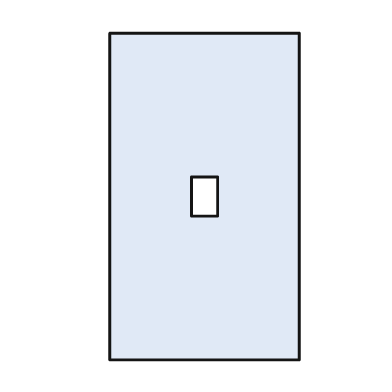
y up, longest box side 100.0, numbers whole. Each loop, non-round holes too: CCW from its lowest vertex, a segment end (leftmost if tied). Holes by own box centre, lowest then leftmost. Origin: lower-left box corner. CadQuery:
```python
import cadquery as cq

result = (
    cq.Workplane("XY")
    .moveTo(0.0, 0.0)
    .lineTo(58.0, 0.0)
    .lineTo(58.0, 100.0)
    .lineTo(0.0, 100.0)
    .close()
    .moveTo(25.0, 44.0)
    .lineTo(33.0, 44.0)
    .lineTo(33.0, 56.0)
    .lineTo(25.0, 56.0)
    .close()
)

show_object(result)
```